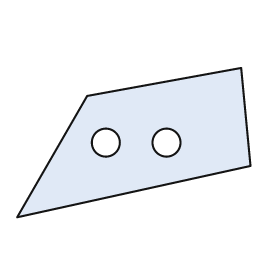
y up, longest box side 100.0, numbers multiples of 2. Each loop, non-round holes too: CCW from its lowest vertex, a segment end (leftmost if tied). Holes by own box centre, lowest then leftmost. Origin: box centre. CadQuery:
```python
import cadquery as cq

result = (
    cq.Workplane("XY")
    .moveTo(-50.0, -32.0)
    .lineTo(50.0, -10.0)
    .lineTo(46.0, 32.0)
    .lineTo(-20.0, 20.0)
    .close()
    .moveTo(-12.0, 0.0)
    .circle(6.0)
    .moveTo(14.0, 0.0)
    .circle(6.0)
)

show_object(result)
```